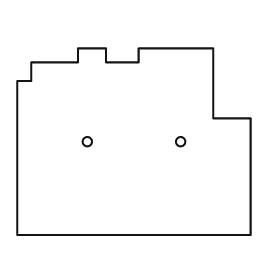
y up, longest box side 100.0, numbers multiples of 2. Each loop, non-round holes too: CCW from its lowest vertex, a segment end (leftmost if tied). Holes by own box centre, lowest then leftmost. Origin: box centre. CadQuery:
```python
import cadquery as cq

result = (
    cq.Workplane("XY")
    .moveTo(-50.0, -40.0)
    .lineTo(50.0, -40.0)
    .lineTo(50.0, 10.0)
    .lineTo(34.0, 10.0)
    .lineTo(34.0, 40.0)
    .lineTo(2.0, 40.0)
    .lineTo(2.0, 34.0)
    .lineTo(-12.0, 34.0)
    .lineTo(-12.0, 40.0)
    .lineTo(-24.0, 40.0)
    .lineTo(-24.0, 34.0)
    .lineTo(-44.0, 34.0)
    .lineTo(-44.0, 26.0)
    .lineTo(-50.0, 26.0)
    .close()
    .moveTo(-20.0, 0.0)
    .circle(2.0)
    .moveTo(20.0, 0.0)
    .circle(2.0)
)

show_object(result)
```